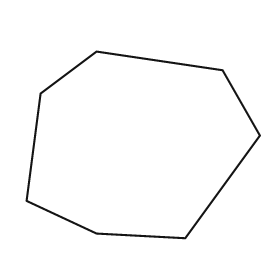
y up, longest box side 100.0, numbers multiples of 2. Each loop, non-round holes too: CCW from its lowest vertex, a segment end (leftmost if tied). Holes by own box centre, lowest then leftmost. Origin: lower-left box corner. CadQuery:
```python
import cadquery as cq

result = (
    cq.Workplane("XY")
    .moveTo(68.0, 0.0)
    .lineTo(100.0, 44.0)
    .lineTo(84.0, 72.0)
    .lineTo(30.0, 80.0)
    .lineTo(6.0, 62.0)
    .lineTo(0.0, 16.0)
    .lineTo(30.0, 2.0)
    .close()
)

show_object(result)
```